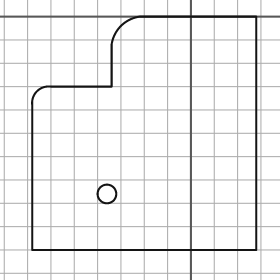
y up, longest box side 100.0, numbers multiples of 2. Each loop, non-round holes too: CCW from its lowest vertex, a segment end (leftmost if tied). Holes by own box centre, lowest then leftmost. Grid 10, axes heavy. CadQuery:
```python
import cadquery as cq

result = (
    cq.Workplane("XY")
    .moveTo(-68.0, -100.0)
    .lineTo(28.0, -100.0)
    .lineTo(28.0, 0.0)
    .lineTo(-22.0, 0.0)
    .threePointArc((-30.0, -4.0), (-34.0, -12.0))
    .lineTo(-34.0, -30.0)
    .lineTo(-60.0, -30.0)
    .threePointArc((-66.0, -32.0), (-68.0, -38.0))
    .close()
    .moveTo(-36.0, -76.0)
    .circle(4.0)
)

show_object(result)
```